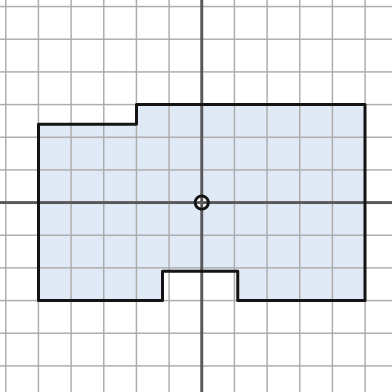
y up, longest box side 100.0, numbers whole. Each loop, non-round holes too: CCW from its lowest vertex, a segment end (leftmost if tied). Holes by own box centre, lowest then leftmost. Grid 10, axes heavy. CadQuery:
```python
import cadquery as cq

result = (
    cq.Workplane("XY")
    .moveTo(-50.0, -30.0)
    .lineTo(-12.0, -30.0)
    .lineTo(-12.0, -21.0)
    .lineTo(11.0, -21.0)
    .lineTo(11.0, -30.0)
    .lineTo(50.0, -30.0)
    .lineTo(50.0, 30.0)
    .lineTo(-20.0, 30.0)
    .lineTo(-20.0, 24.0)
    .lineTo(-50.0, 24.0)
    .close()
    .moveTo(0.0, 0.0)
    .circle(2.0)
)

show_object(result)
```